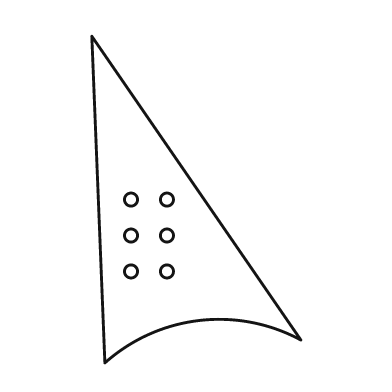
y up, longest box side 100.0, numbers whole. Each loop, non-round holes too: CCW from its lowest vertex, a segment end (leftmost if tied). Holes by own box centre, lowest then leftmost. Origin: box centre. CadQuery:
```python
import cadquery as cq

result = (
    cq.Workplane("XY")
    .moveTo(-28.0, -50.0)
    .threePointArc((1.0, -37.0), (32.0, -43.0))
    .lineTo(-32.0, 50.0)
    .close()
    .moveTo(-20.0, -22.0)
    .circle(2.0)
    .moveTo(-9.0, -22.0)
    .circle(2.0)
    .moveTo(-20.0, -11.0)
    .circle(2.0)
    .moveTo(-9.0, -11.0)
    .circle(2.0)
    .moveTo(-20.0, 0.0)
    .circle(2.0)
    .moveTo(-9.0, 0.0)
    .circle(2.0)
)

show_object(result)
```